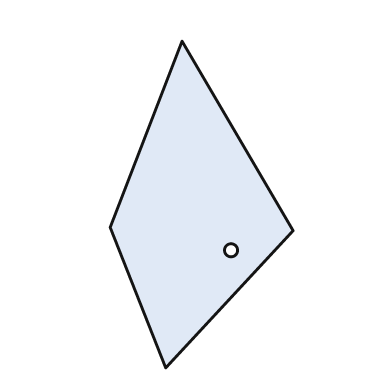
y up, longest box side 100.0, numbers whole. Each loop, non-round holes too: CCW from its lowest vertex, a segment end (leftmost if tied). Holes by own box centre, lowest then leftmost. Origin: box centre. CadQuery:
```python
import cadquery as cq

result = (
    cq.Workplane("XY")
    .moveTo(-11.0, -50.0)
    .lineTo(28.0, -8.0)
    .lineTo(-6.0, 50.0)
    .lineTo(-28.0, -7.0)
    .close()
    .moveTo(9.0, -14.0)
    .circle(2.0)
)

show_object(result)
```